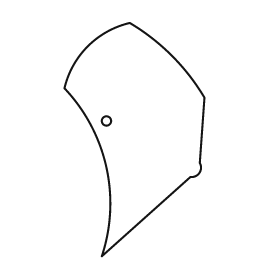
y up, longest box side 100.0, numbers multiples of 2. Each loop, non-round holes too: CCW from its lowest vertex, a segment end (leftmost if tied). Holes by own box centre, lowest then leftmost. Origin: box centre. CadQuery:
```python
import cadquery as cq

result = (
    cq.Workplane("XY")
    .moveTo(-14.0, -50.0)
    .lineTo(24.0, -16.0)
    .threePointArc((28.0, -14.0), (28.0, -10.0))
    .lineTo(30.0, 18.0)
    .threePointArc((16.0, 36.0), (-2.0, 50.0))
    .threePointArc((-20.0, 40.0), (-30.0, 22.0))
    .threePointArc((-12.0, -12.0), (-14.0, -50.0))
    .close()
    .moveTo(-12.0, 8.0)
    .circle(2.0)
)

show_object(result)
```